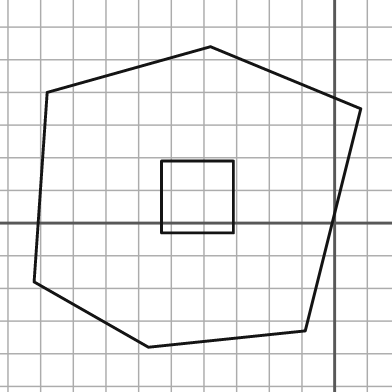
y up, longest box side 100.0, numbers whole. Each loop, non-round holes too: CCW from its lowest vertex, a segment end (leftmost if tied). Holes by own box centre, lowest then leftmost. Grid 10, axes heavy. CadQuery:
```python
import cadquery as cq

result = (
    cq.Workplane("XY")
    .moveTo(-57.0, -38.0)
    .lineTo(-9.0, -33.0)
    .lineTo(8.0, 35.0)
    .lineTo(-38.0, 54.0)
    .lineTo(-88.0, 40.0)
    .lineTo(-92.0, -18.0)
    .close()
    .moveTo(-53.0, -3.0)
    .lineTo(-31.0, -3.0)
    .lineTo(-31.0, 19.0)
    .lineTo(-53.0, 19.0)
    .close()
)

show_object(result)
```